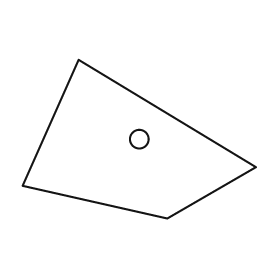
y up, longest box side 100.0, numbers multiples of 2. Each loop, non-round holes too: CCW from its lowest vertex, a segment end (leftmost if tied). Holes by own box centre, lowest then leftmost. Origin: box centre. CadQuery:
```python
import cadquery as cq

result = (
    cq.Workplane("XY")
    .moveTo(12.0, -34.0)
    .lineTo(50.0, -12.0)
    .lineTo(-26.0, 34.0)
    .lineTo(-50.0, -20.0)
    .close()
    .moveTo(0.0, 0.0)
    .circle(4.0)
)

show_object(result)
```